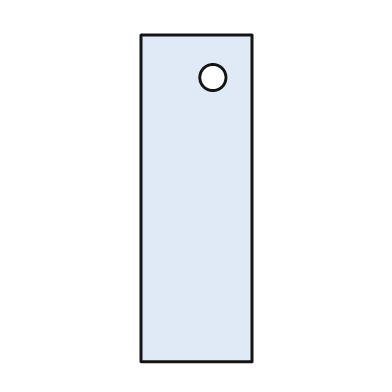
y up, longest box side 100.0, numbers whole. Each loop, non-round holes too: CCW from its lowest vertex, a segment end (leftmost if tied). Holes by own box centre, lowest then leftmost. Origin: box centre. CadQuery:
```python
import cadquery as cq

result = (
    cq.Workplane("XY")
    .moveTo(-17.0, -50.0)
    .lineTo(17.0, -50.0)
    .lineTo(17.0, 50.0)
    .lineTo(-17.0, 50.0)
    .close()
    .moveTo(5.0, 37.0)
    .circle(4.0)
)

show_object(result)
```